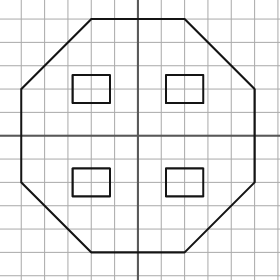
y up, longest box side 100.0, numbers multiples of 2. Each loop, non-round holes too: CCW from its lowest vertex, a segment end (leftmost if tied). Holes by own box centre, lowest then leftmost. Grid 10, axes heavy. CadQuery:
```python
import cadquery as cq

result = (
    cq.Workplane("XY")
    .moveTo(-20.0, -50.0)
    .lineTo(20.0, -50.0)
    .lineTo(50.0, -20.0)
    .lineTo(50.0, 20.0)
    .lineTo(20.0, 50.0)
    .lineTo(-20.0, 50.0)
    .lineTo(-50.0, 20.0)
    .lineTo(-50.0, -20.0)
    .close()
    .moveTo(-28.0, -26.0)
    .lineTo(-12.0, -26.0)
    .lineTo(-12.0, -14.0)
    .lineTo(-28.0, -14.0)
    .close()
    .moveTo(12.0, -26.0)
    .lineTo(28.0, -26.0)
    .lineTo(28.0, -14.0)
    .lineTo(12.0, -14.0)
    .close()
    .moveTo(-28.0, 14.0)
    .lineTo(-12.0, 14.0)
    .lineTo(-12.0, 26.0)
    .lineTo(-28.0, 26.0)
    .close()
    .moveTo(12.0, 14.0)
    .lineTo(28.0, 14.0)
    .lineTo(28.0, 26.0)
    .lineTo(12.0, 26.0)
    .close()
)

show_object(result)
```